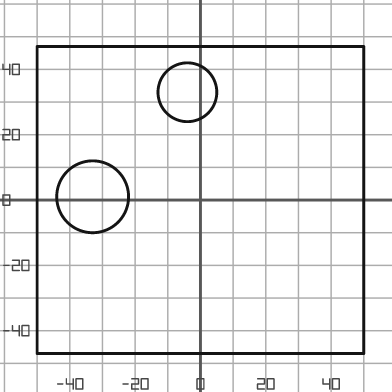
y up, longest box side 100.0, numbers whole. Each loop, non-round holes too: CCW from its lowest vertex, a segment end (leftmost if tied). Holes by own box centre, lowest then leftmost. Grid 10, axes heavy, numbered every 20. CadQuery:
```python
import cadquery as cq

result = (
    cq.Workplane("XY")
    .moveTo(-50.0, -47.0)
    .lineTo(50.0, -47.0)
    .lineTo(50.0, 47.0)
    .lineTo(-50.0, 47.0)
    .close()
    .moveTo(-33.0, 1.0)
    .circle(11.0)
    .moveTo(-4.0, 33.0)
    .circle(9.0)
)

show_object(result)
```